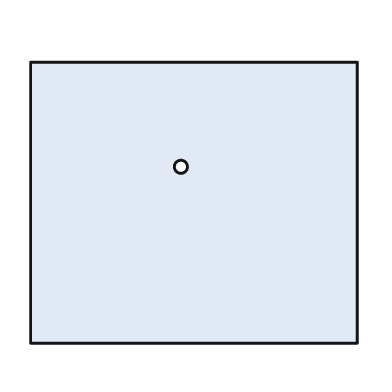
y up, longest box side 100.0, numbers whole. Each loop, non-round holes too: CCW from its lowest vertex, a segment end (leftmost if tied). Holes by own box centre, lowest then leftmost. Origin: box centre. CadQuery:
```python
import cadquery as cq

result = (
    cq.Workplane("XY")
    .moveTo(-50.0, -43.0)
    .lineTo(50.0, -43.0)
    .lineTo(50.0, 43.0)
    .lineTo(-50.0, 43.0)
    .close()
    .moveTo(-4.0, 11.0)
    .circle(2.0)
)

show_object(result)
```